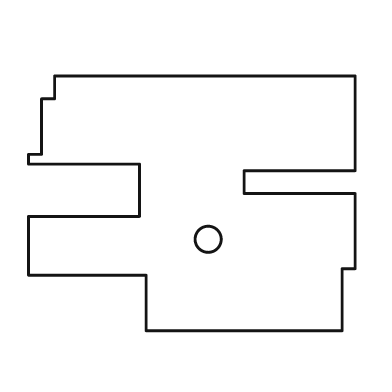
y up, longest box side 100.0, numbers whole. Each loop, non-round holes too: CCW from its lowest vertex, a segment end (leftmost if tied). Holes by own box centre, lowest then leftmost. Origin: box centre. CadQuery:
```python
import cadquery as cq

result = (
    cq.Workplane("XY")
    .moveTo(-14.0, -39.0)
    .lineTo(46.0, -39.0)
    .lineTo(46.0, -20.0)
    .lineTo(50.0, -20.0)
    .lineTo(50.0, 3.0)
    .lineTo(16.0, 3.0)
    .lineTo(16.0, 10.0)
    .lineTo(50.0, 10.0)
    .lineTo(50.0, 39.0)
    .lineTo(-42.0, 39.0)
    .lineTo(-42.0, 32.0)
    .lineTo(-46.0, 32.0)
    .lineTo(-46.0, 15.0)
    .lineTo(-50.0, 15.0)
    .lineTo(-50.0, 12.0)
    .lineTo(-16.0, 12.0)
    .lineTo(-16.0, -4.0)
    .lineTo(-50.0, -4.0)
    .lineTo(-50.0, -22.0)
    .lineTo(-14.0, -22.0)
    .close()
    .moveTo(5.0, -11.0)
    .circle(4.0)
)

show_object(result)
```